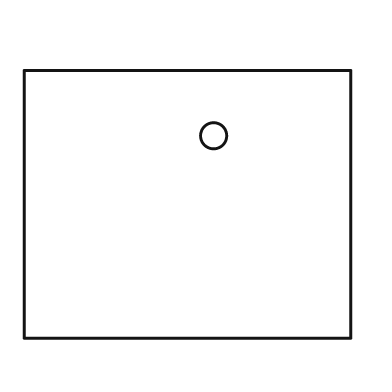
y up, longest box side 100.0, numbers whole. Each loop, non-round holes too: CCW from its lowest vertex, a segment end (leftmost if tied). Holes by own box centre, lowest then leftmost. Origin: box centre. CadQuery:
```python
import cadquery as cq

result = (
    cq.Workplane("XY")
    .moveTo(-50.0, -41.0)
    .lineTo(50.0, -41.0)
    .lineTo(50.0, 41.0)
    .lineTo(-50.0, 41.0)
    .close()
    .moveTo(8.0, 21.0)
    .circle(4.0)
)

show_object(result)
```